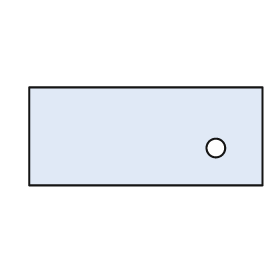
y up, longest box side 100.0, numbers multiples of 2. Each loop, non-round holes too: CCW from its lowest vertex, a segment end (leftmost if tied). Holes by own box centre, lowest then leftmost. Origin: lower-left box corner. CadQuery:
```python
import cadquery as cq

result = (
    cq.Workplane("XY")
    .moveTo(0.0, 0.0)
    .lineTo(100.0, 0.0)
    .lineTo(100.0, 42.0)
    .lineTo(0.0, 42.0)
    .close()
    .moveTo(80.0, 16.0)
    .circle(4.0)
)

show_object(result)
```